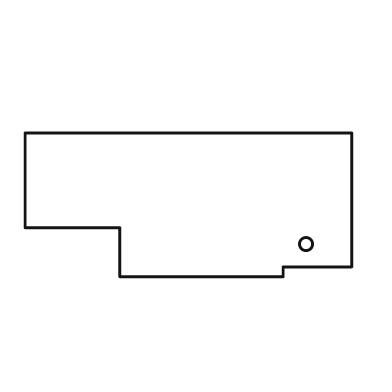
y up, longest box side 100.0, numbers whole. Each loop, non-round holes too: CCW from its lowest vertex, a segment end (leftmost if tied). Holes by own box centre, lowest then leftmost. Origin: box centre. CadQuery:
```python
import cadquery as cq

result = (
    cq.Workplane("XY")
    .moveTo(-21.0, -22.0)
    .lineTo(29.0, -22.0)
    .lineTo(29.0, -19.0)
    .lineTo(50.0, -19.0)
    .lineTo(50.0, 22.0)
    .lineTo(-50.0, 22.0)
    .lineTo(-50.0, -7.0)
    .lineTo(-21.0, -7.0)
    .close()
    .moveTo(36.0, -12.0)
    .circle(2.0)
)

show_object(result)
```